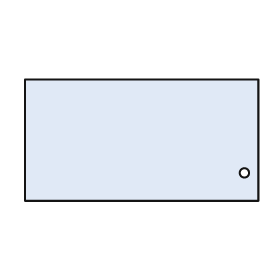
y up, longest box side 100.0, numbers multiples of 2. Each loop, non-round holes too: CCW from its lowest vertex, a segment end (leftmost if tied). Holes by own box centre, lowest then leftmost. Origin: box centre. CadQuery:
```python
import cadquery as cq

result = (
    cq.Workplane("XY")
    .moveTo(-50.0, -26.0)
    .lineTo(50.0, -26.0)
    .lineTo(50.0, 26.0)
    .lineTo(-50.0, 26.0)
    .close()
    .moveTo(44.0, -14.0)
    .circle(2.0)
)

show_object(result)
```